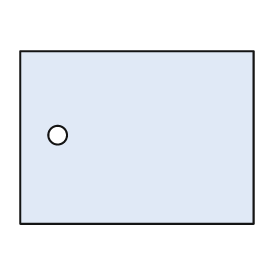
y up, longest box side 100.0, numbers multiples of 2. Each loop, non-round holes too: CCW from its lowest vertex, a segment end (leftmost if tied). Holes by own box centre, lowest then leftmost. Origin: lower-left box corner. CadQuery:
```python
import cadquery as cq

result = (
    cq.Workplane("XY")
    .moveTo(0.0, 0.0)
    .lineTo(100.0, 0.0)
    .lineTo(100.0, 74.0)
    .lineTo(0.0, 74.0)
    .close()
    .moveTo(16.0, 38.0)
    .circle(4.0)
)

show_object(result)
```